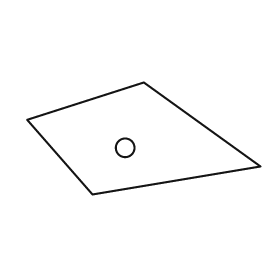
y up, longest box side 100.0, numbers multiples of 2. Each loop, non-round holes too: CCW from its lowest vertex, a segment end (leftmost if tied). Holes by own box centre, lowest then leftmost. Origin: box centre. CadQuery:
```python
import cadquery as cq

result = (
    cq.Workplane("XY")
    .moveTo(-22.0, -24.0)
    .lineTo(50.0, -12.0)
    .lineTo(0.0, 24.0)
    .lineTo(-50.0, 8.0)
    .close()
    .moveTo(-8.0, -4.0)
    .circle(4.0)
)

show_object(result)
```